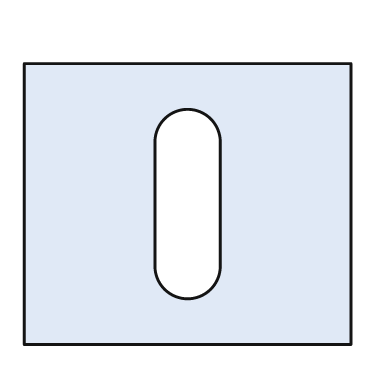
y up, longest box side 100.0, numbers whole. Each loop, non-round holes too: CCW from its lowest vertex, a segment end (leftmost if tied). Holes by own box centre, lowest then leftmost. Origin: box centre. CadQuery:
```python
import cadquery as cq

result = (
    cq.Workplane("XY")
    .moveTo(-50.0, -43.0)
    .lineTo(50.0, -43.0)
    .lineTo(50.0, 43.0)
    .lineTo(-50.0, 43.0)
    .close()
    .moveTo(-10.0, -19.0)
    .threePointArc((0.0, -29.0), (10.0, -19.0))
    .lineTo(10.0, 19.0)
    .threePointArc((0.0, 29.0), (-10.0, 19.0))
    .close()
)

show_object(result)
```